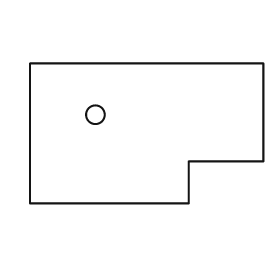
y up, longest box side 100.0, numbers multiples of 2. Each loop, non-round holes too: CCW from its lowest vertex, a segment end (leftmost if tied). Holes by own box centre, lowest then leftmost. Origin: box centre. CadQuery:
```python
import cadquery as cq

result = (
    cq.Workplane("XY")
    .moveTo(-50.0, -30.0)
    .lineTo(18.0, -30.0)
    .lineTo(18.0, -12.0)
    .lineTo(50.0, -12.0)
    .lineTo(50.0, 30.0)
    .lineTo(-50.0, 30.0)
    .close()
    .moveTo(-22.0, 8.0)
    .circle(4.0)
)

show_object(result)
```